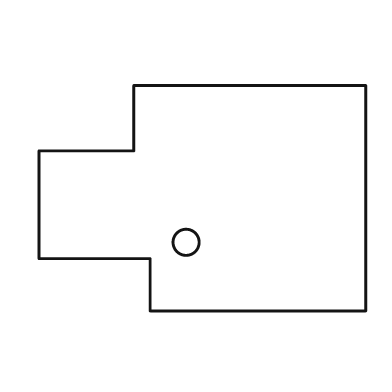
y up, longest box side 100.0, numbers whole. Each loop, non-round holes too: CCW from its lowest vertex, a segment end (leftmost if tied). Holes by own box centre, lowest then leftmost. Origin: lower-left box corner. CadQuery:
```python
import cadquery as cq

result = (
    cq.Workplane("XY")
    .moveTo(34.0, 0.0)
    .lineTo(100.0, 0.0)
    .lineTo(100.0, 69.0)
    .lineTo(29.0, 69.0)
    .lineTo(29.0, 49.0)
    .lineTo(0.0, 49.0)
    .lineTo(0.0, 16.0)
    .lineTo(34.0, 16.0)
    .close()
    .moveTo(45.0, 21.0)
    .circle(4.0)
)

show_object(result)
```